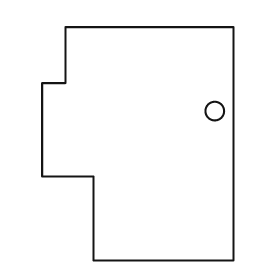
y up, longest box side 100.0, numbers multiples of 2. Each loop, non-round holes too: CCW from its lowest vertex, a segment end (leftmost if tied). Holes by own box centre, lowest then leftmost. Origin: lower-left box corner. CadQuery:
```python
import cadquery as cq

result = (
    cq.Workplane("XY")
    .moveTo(22.0, 0.0)
    .lineTo(82.0, 0.0)
    .lineTo(82.0, 100.0)
    .lineTo(10.0, 100.0)
    .lineTo(10.0, 76.0)
    .lineTo(0.0, 76.0)
    .lineTo(0.0, 36.0)
    .lineTo(22.0, 36.0)
    .close()
    .moveTo(74.0, 64.0)
    .circle(4.0)
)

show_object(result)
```